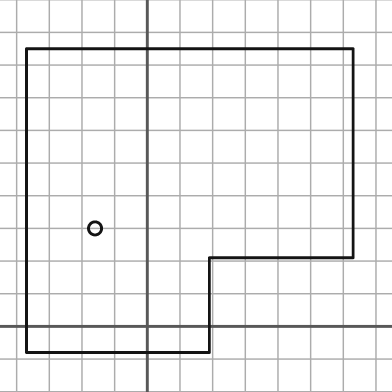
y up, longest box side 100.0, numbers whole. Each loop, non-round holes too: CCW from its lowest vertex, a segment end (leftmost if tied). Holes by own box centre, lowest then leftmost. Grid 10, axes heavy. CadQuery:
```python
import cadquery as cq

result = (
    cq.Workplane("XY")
    .moveTo(-37.0, -8.0)
    .lineTo(19.0, -8.0)
    .lineTo(19.0, 21.0)
    .lineTo(63.0, 21.0)
    .lineTo(63.0, 85.0)
    .lineTo(-37.0, 85.0)
    .close()
    .moveTo(-16.0, 30.0)
    .circle(2.0)
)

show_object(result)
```